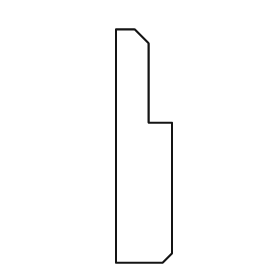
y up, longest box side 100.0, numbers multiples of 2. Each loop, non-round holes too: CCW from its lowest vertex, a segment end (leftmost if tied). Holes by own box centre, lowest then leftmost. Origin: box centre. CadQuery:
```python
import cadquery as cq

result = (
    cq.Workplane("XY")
    .moveTo(-12.0, -50.0)
    .lineTo(8.0, -50.0)
    .lineTo(12.0, -46.0)
    .lineTo(12.0, 10.0)
    .lineTo(2.0, 10.0)
    .lineTo(2.0, 44.0)
    .lineTo(-4.0, 50.0)
    .lineTo(-12.0, 50.0)
    .close()
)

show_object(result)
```